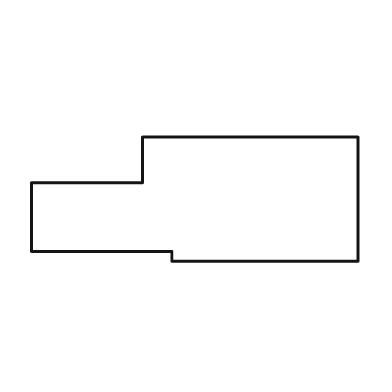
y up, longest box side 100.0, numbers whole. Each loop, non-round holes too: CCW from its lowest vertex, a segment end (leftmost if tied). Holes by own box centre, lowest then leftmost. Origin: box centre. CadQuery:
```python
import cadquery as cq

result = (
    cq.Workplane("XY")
    .moveTo(-7.0, -19.0)
    .lineTo(50.0, -19.0)
    .lineTo(50.0, 19.0)
    .lineTo(-16.0, 19.0)
    .lineTo(-16.0, 5.0)
    .lineTo(-50.0, 5.0)
    .lineTo(-50.0, -16.0)
    .lineTo(-7.0, -16.0)
    .close()
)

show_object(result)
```